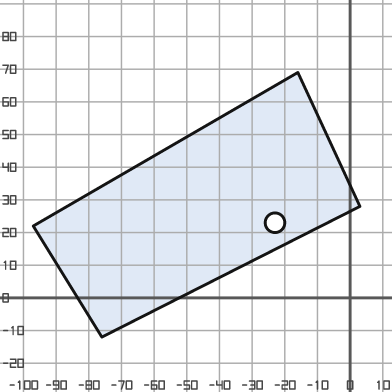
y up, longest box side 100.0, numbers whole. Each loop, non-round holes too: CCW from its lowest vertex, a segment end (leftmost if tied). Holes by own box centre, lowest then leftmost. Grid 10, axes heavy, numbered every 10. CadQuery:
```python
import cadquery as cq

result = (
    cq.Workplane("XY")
    .moveTo(-76.0, -12.0)
    .lineTo(3.0, 28.0)
    .lineTo(-16.0, 69.0)
    .lineTo(-97.0, 22.0)
    .close()
    .moveTo(-23.0, 23.0)
    .circle(3.0)
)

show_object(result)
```